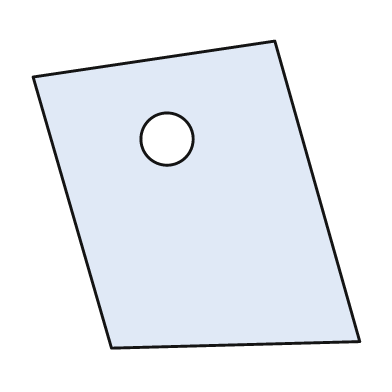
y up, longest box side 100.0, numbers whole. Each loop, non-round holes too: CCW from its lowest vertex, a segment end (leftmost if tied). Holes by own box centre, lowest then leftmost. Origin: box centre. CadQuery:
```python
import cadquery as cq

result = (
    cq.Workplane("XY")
    .moveTo(-26.0, -47.0)
    .lineTo(50.0, -45.0)
    .lineTo(24.0, 47.0)
    .lineTo(-50.0, 36.0)
    .close()
    .moveTo(-9.0, 17.0)
    .circle(8.0)
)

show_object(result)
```